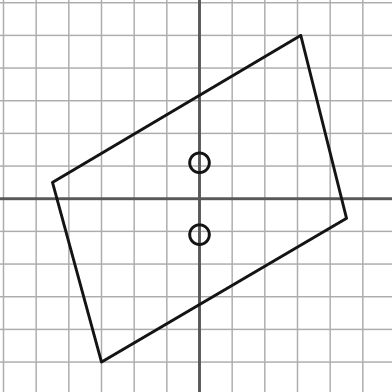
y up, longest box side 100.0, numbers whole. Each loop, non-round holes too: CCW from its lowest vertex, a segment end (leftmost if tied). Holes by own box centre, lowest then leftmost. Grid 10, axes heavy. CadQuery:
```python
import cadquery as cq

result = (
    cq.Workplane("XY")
    .moveTo(-30.0, -50.0)
    .lineTo(45.0, -6.0)
    .lineTo(31.0, 50.0)
    .lineTo(-45.0, 5.0)
    .close()
    .moveTo(0.0, -11.0)
    .circle(3.0)
    .moveTo(0.0, 11.0)
    .circle(3.0)
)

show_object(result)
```